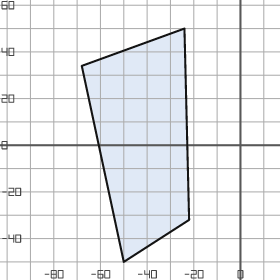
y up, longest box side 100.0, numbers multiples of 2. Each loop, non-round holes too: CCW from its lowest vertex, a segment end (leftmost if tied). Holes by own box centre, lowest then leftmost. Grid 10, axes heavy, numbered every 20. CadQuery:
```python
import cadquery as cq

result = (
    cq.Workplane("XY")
    .moveTo(-50.0, -50.0)
    .lineTo(-22.0, -32.0)
    .lineTo(-24.0, 50.0)
    .lineTo(-68.0, 34.0)
    .close()
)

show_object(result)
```